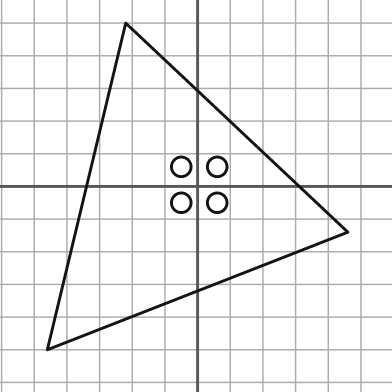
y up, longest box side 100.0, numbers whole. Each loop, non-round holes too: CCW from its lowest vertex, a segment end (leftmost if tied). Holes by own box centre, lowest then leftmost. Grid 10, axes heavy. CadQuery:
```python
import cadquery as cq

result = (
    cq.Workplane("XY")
    .moveTo(-46.0, -50.0)
    .lineTo(46.0, -14.0)
    .lineTo(-22.0, 50.0)
    .close()
    .moveTo(-5.0, -5.0)
    .circle(3.0)
    .moveTo(6.0, -5.0)
    .circle(3.0)
    .moveTo(-5.0, 6.0)
    .circle(3.0)
    .moveTo(6.0, 6.0)
    .circle(3.0)
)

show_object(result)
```